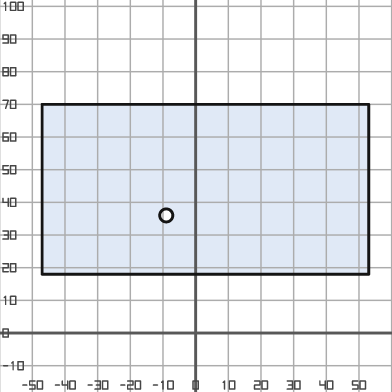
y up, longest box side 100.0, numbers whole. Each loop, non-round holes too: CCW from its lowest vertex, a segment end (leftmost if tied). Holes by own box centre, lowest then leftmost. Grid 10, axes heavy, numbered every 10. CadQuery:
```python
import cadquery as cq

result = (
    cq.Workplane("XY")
    .moveTo(-47.0, 18.0)
    .lineTo(53.0, 18.0)
    .lineTo(53.0, 70.0)
    .lineTo(-47.0, 70.0)
    .close()
    .moveTo(-9.0, 36.0)
    .circle(2.0)
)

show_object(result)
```